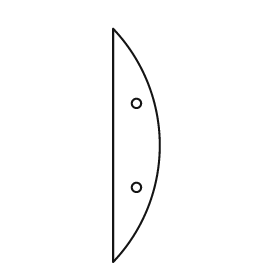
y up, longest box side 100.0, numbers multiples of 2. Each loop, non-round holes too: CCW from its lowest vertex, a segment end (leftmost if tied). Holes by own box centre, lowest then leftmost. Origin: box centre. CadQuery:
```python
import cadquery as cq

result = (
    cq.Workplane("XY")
    .moveTo(-10.0, -50.0)
    .threePointArc((10.0, 0.0), (-10.0, 50.0))
    .close()
    .moveTo(0.0, -18.0)
    .circle(2.0)
    .moveTo(0.0, 18.0)
    .circle(2.0)
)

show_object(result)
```